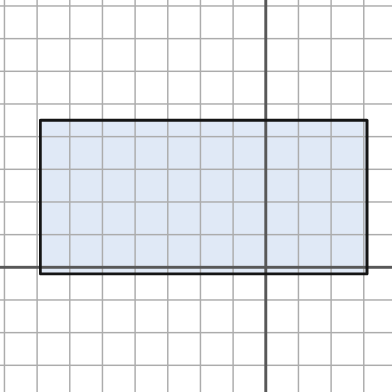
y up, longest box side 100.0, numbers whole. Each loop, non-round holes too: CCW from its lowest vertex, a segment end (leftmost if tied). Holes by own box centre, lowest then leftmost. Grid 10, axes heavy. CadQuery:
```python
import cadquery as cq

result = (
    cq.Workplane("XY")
    .moveTo(-69.0, -2.0)
    .lineTo(31.0, -2.0)
    .lineTo(31.0, 45.0)
    .lineTo(-69.0, 45.0)
    .close()
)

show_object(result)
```